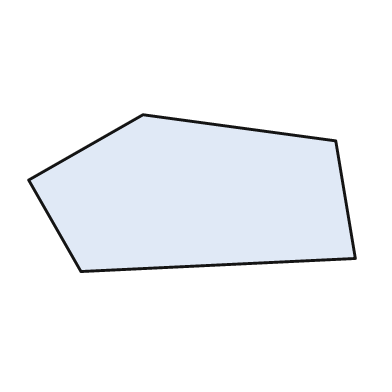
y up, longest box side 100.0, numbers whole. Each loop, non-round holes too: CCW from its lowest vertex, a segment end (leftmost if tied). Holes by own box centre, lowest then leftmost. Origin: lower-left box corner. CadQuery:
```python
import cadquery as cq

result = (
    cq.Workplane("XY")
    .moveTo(16.0, 0.0)
    .lineTo(100.0, 4.0)
    .lineTo(94.0, 40.0)
    .lineTo(35.0, 48.0)
    .lineTo(0.0, 28.0)
    .close()
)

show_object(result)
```